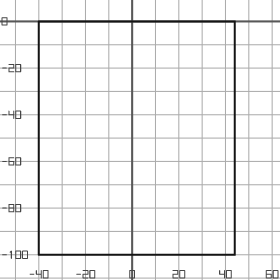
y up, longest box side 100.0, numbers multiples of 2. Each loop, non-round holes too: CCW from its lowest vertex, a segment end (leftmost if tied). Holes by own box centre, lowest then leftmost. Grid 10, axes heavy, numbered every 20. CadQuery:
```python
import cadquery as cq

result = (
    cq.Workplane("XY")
    .moveTo(-40.0, -100.0)
    .lineTo(44.0, -100.0)
    .lineTo(44.0, 0.0)
    .lineTo(-40.0, 0.0)
    .close()
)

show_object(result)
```